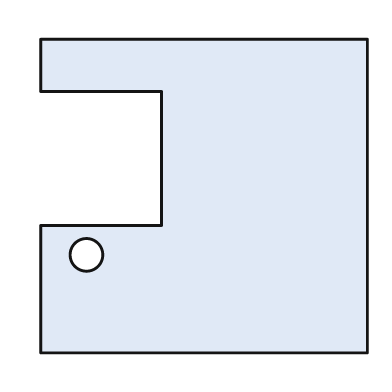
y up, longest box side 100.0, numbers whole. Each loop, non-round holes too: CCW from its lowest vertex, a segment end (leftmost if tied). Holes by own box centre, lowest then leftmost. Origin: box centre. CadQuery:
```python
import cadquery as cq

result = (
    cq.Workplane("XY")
    .moveTo(-50.0, -48.0)
    .lineTo(50.0, -48.0)
    .lineTo(50.0, 48.0)
    .lineTo(-50.0, 48.0)
    .lineTo(-50.0, 32.0)
    .lineTo(-13.0, 32.0)
    .lineTo(-13.0, -9.0)
    .lineTo(-50.0, -9.0)
    .close()
    .moveTo(-36.0, -18.0)
    .circle(5.0)
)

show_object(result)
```